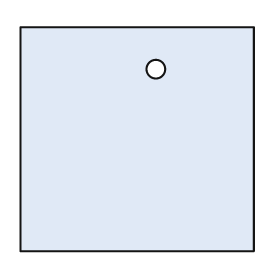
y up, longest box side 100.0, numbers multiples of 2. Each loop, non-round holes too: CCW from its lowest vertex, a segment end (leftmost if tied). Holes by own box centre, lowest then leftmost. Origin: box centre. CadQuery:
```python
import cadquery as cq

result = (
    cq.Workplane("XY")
    .moveTo(-50.0, -48.0)
    .lineTo(50.0, -48.0)
    .lineTo(50.0, 48.0)
    .lineTo(-50.0, 48.0)
    .close()
    .moveTo(8.0, 30.0)
    .circle(4.0)
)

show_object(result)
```